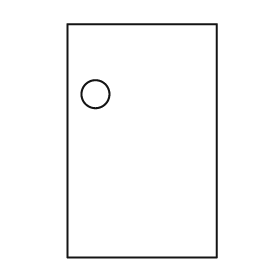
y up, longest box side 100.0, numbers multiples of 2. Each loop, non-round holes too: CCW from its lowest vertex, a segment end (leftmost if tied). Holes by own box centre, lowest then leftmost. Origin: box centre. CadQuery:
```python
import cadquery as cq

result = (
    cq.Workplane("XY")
    .moveTo(-32.0, -50.0)
    .lineTo(32.0, -50.0)
    .lineTo(32.0, 50.0)
    .lineTo(-32.0, 50.0)
    .close()
    .moveTo(-20.0, 20.0)
    .circle(6.0)
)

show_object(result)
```